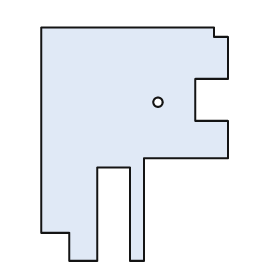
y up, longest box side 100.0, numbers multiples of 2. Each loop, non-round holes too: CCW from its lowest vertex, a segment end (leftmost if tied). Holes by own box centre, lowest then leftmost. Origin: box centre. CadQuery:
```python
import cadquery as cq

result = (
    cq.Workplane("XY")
    .moveTo(-28.0, -50.0)
    .lineTo(-16.0, -50.0)
    .lineTo(-16.0, -10.0)
    .lineTo(-2.0, -10.0)
    .lineTo(-2.0, -50.0)
    .lineTo(4.0, -50.0)
    .lineTo(4.0, -6.0)
    .lineTo(40.0, -6.0)
    .lineTo(40.0, 10.0)
    .lineTo(26.0, 10.0)
    .lineTo(26.0, 28.0)
    .lineTo(40.0, 28.0)
    .lineTo(40.0, 46.0)
    .lineTo(34.0, 46.0)
    .lineTo(34.0, 50.0)
    .lineTo(-40.0, 50.0)
    .lineTo(-40.0, -38.0)
    .lineTo(-28.0, -38.0)
    .close()
    .moveTo(10.0, 18.0)
    .circle(2.0)
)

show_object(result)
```